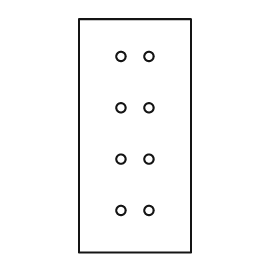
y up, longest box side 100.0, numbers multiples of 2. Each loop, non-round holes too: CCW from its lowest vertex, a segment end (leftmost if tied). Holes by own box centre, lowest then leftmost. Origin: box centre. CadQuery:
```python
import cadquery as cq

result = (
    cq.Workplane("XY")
    .moveTo(-24.0, -50.0)
    .lineTo(24.0, -50.0)
    .lineTo(24.0, 50.0)
    .lineTo(-24.0, 50.0)
    .close()
    .moveTo(-6.0, -32.0)
    .circle(2.0)
    .moveTo(6.0, -32.0)
    .circle(2.0)
    .moveTo(-6.0, -10.0)
    .circle(2.0)
    .moveTo(6.0, -10.0)
    .circle(2.0)
    .moveTo(-6.0, 12.0)
    .circle(2.0)
    .moveTo(6.0, 12.0)
    .circle(2.0)
    .moveTo(-6.0, 34.0)
    .circle(2.0)
    .moveTo(6.0, 34.0)
    .circle(2.0)
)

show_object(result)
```